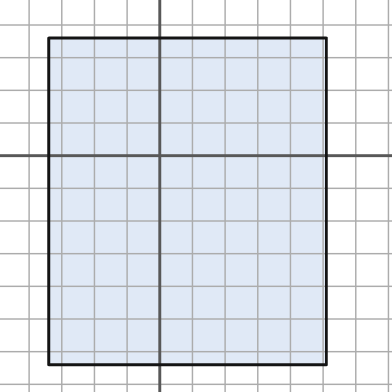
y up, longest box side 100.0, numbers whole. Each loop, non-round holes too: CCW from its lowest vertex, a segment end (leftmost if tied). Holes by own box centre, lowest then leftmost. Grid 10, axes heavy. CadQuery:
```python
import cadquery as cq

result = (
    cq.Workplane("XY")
    .moveTo(-34.0, -64.0)
    .lineTo(51.0, -64.0)
    .lineTo(51.0, 36.0)
    .lineTo(-34.0, 36.0)
    .close()
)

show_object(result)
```